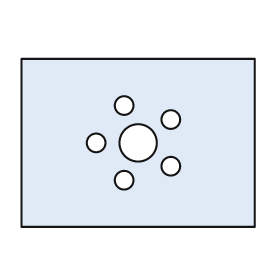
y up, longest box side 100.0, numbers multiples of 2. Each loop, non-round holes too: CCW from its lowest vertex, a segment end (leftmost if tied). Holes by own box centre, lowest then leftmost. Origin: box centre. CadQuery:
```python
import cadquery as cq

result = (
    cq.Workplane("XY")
    .moveTo(-50.0, -36.0)
    .lineTo(50.0, -36.0)
    .lineTo(50.0, 36.0)
    .lineTo(-50.0, 36.0)
    .close()
    .moveTo(-6.0, -16.0)
    .circle(4.0)
    .moveTo(14.0, -10.0)
    .circle(4.0)
    .moveTo(-18.0, 0.0)
    .circle(4.0)
    .moveTo(0.0, 0.0)
    .circle(8.0)
    .moveTo(14.0, 10.0)
    .circle(4.0)
    .moveTo(-6.0, 16.0)
    .circle(4.0)
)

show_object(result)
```